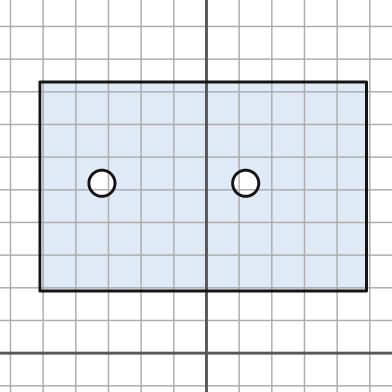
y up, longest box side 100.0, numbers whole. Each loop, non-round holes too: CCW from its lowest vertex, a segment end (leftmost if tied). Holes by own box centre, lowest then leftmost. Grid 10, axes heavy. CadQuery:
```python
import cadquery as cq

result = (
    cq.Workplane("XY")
    .moveTo(-51.0, 19.0)
    .lineTo(49.0, 19.0)
    .lineTo(49.0, 83.0)
    .lineTo(-51.0, 83.0)
    .close()
    .moveTo(-32.0, 52.0)
    .circle(4.0)
    .moveTo(12.0, 52.0)
    .circle(4.0)
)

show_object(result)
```